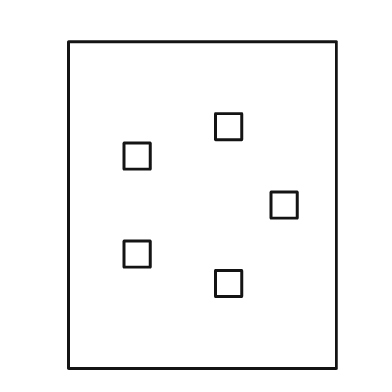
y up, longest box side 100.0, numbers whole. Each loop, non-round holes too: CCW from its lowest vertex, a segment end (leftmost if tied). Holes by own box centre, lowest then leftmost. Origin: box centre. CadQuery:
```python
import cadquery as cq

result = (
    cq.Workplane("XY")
    .moveTo(-41.0, -50.0)
    .lineTo(41.0, -50.0)
    .lineTo(41.0, 50.0)
    .lineTo(-41.0, 50.0)
    .close()
    .moveTo(4.0, -28.0)
    .lineTo(12.0, -28.0)
    .lineTo(12.0, -20.0)
    .lineTo(4.0, -20.0)
    .close()
    .moveTo(-24.0, -19.0)
    .lineTo(-16.0, -19.0)
    .lineTo(-16.0, -11.0)
    .lineTo(-24.0, -11.0)
    .close()
    .moveTo(21.0, -4.0)
    .lineTo(29.0, -4.0)
    .lineTo(29.0, 4.0)
    .lineTo(21.0, 4.0)
    .close()
    .moveTo(-24.0, 11.0)
    .lineTo(-16.0, 11.0)
    .lineTo(-16.0, 19.0)
    .lineTo(-24.0, 19.0)
    .close()
    .moveTo(4.0, 20.0)
    .lineTo(12.0, 20.0)
    .lineTo(12.0, 28.0)
    .lineTo(4.0, 28.0)
    .close()
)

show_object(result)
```